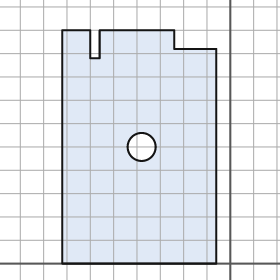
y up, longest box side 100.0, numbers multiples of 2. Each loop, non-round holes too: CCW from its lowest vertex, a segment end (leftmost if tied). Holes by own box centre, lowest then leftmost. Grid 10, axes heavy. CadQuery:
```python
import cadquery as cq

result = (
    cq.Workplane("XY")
    .moveTo(-72.0, 0.0)
    .lineTo(-6.0, 0.0)
    .lineTo(-6.0, 92.0)
    .lineTo(-24.0, 92.0)
    .lineTo(-24.0, 100.0)
    .lineTo(-56.0, 100.0)
    .lineTo(-56.0, 88.0)
    .lineTo(-60.0, 88.0)
    .lineTo(-60.0, 100.0)
    .lineTo(-72.0, 100.0)
    .close()
    .moveTo(-38.0, 50.0)
    .circle(6.0)
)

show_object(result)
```